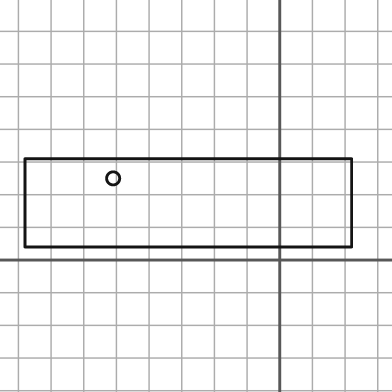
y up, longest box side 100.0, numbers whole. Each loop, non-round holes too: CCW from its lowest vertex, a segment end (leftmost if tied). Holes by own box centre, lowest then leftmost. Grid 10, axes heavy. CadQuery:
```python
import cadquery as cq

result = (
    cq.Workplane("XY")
    .moveTo(-78.0, 4.0)
    .lineTo(22.0, 4.0)
    .lineTo(22.0, 31.0)
    .lineTo(-78.0, 31.0)
    .close()
    .moveTo(-51.0, 25.0)
    .circle(2.0)
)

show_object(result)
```